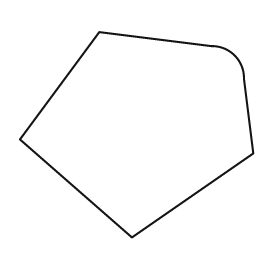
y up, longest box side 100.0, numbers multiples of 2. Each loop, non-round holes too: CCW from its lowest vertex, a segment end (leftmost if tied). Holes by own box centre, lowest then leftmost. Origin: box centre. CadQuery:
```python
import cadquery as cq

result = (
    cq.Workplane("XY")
    .moveTo(-2.0, -44.0)
    .lineTo(50.0, -8.0)
    .lineTo(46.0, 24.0)
    .threePointArc((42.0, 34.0), (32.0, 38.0))
    .lineTo(-16.0, 44.0)
    .lineTo(-50.0, -2.0)
    .close()
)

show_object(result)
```